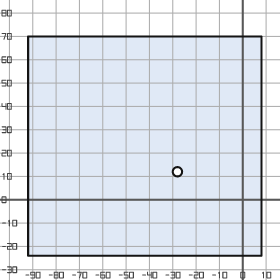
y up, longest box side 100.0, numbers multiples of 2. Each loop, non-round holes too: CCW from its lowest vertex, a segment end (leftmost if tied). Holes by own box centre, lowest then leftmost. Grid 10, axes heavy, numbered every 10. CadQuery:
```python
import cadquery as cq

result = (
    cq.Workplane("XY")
    .moveTo(-92.0, -24.0)
    .lineTo(8.0, -24.0)
    .lineTo(8.0, 70.0)
    .lineTo(-92.0, 70.0)
    .close()
    .moveTo(-28.0, 12.0)
    .circle(2.0)
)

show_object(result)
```